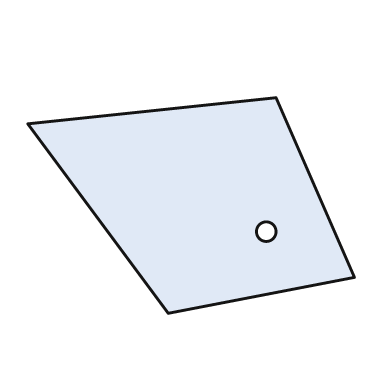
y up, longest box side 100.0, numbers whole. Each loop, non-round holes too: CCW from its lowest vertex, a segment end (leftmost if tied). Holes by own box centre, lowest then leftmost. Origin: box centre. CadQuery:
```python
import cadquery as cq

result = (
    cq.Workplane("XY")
    .moveTo(-7.0, -33.0)
    .lineTo(50.0, -22.0)
    .lineTo(26.0, 33.0)
    .lineTo(-50.0, 25.0)
    .close()
    .moveTo(23.0, -8.0)
    .circle(3.0)
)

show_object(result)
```